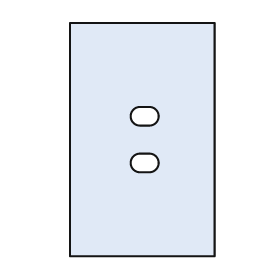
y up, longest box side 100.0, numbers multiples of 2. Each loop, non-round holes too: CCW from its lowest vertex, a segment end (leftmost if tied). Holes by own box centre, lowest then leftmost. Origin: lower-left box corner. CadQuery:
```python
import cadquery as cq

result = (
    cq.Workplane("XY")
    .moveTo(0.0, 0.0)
    .lineTo(62.0, 0.0)
    .lineTo(62.0, 100.0)
    .lineTo(0.0, 100.0)
    .close()
    .moveTo(30.0, 36.0)
    .lineTo(34.0, 36.0)
    .threePointArc((38.0, 40.0), (34.0, 44.0))
    .lineTo(30.0, 44.0)
    .threePointArc((26.0, 40.0), (30.0, 36.0))
    .close()
    .moveTo(30.0, 56.0)
    .lineTo(34.0, 56.0)
    .threePointArc((38.0, 60.0), (34.0, 64.0))
    .lineTo(30.0, 64.0)
    .threePointArc((26.0, 60.0), (30.0, 56.0))
    .close()
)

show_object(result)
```